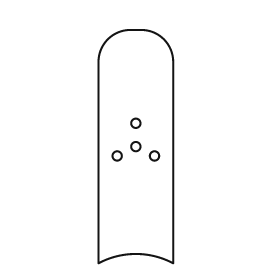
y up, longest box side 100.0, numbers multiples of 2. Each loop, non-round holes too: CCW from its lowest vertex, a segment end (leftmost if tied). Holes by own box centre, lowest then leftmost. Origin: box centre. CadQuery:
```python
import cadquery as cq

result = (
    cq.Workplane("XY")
    .moveTo(-16.0, -50.0)
    .threePointArc((0.0, -46.0), (16.0, -50.0))
    .lineTo(16.0, 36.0)
    .threePointArc((12.0, 46.0), (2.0, 50.0))
    .lineTo(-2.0, 50.0)
    .threePointArc((-12.0, 46.0), (-16.0, 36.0))
    .close()
    .moveTo(-8.0, -4.0)
    .circle(2.0)
    .moveTo(8.0, -4.0)
    .circle(2.0)
    .moveTo(0.0, 0.0)
    .circle(2.0)
    .moveTo(0.0, 10.0)
    .circle(2.0)
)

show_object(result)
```